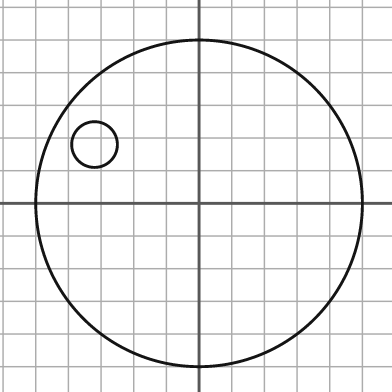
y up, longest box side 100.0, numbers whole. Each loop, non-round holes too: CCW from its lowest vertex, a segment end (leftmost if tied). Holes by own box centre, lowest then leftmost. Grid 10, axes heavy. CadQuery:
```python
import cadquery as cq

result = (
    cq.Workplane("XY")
    .moveTo(0.0, 0.0)
    .circle(50.0)
    .moveTo(-32.0, 18.0)
    .circle(7.0)
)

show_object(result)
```